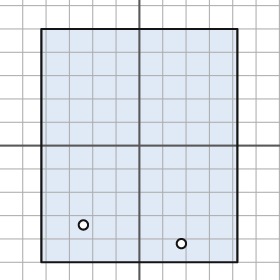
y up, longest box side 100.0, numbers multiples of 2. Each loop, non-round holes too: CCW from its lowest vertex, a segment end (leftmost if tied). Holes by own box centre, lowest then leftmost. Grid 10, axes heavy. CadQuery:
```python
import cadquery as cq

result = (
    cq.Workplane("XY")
    .moveTo(-42.0, -50.0)
    .lineTo(42.0, -50.0)
    .lineTo(42.0, 50.0)
    .lineTo(-42.0, 50.0)
    .close()
    .moveTo(18.0, -42.0)
    .circle(2.0)
    .moveTo(-24.0, -34.0)
    .circle(2.0)
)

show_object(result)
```